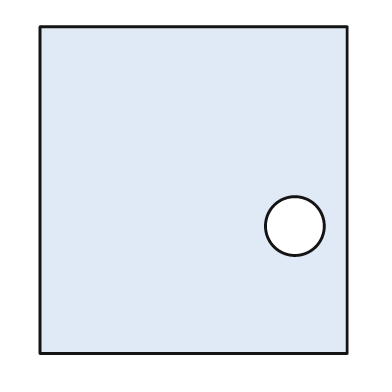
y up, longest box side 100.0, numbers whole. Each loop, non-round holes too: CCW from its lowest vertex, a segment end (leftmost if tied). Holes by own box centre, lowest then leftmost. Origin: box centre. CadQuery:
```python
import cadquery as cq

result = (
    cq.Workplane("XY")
    .moveTo(-47.0, -50.0)
    .lineTo(47.0, -50.0)
    .lineTo(47.0, 50.0)
    .lineTo(-47.0, 50.0)
    .close()
    .moveTo(31.0, -11.0)
    .circle(9.0)
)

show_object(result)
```